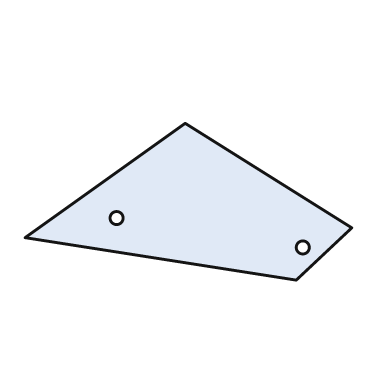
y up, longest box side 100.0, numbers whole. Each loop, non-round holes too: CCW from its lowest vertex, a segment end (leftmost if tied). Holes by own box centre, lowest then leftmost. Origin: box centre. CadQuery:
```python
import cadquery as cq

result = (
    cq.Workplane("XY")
    .moveTo(33.0, -24.0)
    .lineTo(50.0, -8.0)
    .lineTo(-1.0, 24.0)
    .lineTo(-50.0, -11.0)
    .close()
    .moveTo(35.0, -14.0)
    .circle(2.0)
    .moveTo(-22.0, -5.0)
    .circle(2.0)
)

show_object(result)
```